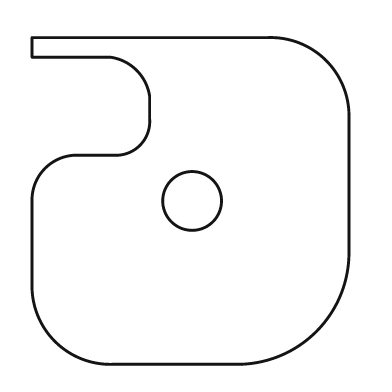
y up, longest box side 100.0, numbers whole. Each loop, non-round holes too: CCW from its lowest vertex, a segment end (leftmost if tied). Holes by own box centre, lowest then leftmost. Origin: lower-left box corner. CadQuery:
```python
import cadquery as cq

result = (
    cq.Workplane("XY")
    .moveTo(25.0, 0.0)
    .lineTo(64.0, 0.0)
    .threePointArc((87.0, 10.0), (97.0, 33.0))
    .lineTo(97.0, 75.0)
    .threePointArc((90.0, 93.0), (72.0, 100.0))
    .lineTo(0.0, 100.0)
    .lineTo(0.0, 94.0)
    .lineTo(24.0, 94.0)
    .threePointArc((32.0, 90.0), (36.0, 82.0))
    .lineTo(36.0, 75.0)
    .threePointArc((33.0, 67.0), (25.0, 64.0))
    .lineTo(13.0, 64.0)
    .threePointArc((4.0, 60.0), (0.0, 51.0))
    .lineTo(0.0, 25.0)
    .threePointArc((7.0, 7.0), (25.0, 0.0))
    .close()
    .moveTo(49.0, 50.0)
    .circle(9.0)
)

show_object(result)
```